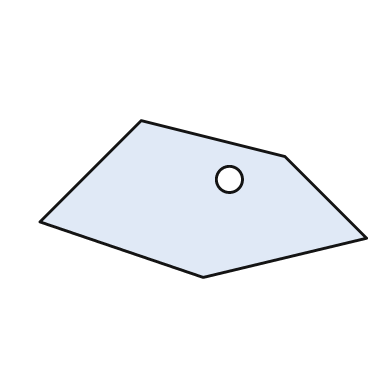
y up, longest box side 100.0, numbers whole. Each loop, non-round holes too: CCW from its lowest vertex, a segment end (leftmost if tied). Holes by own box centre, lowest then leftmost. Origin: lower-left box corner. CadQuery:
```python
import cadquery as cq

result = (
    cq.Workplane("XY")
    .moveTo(50.0, 0.0)
    .lineTo(100.0, 12.0)
    .lineTo(75.0, 37.0)
    .lineTo(31.0, 48.0)
    .lineTo(0.0, 17.0)
    .close()
    .moveTo(58.0, 30.0)
    .circle(4.0)
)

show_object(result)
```